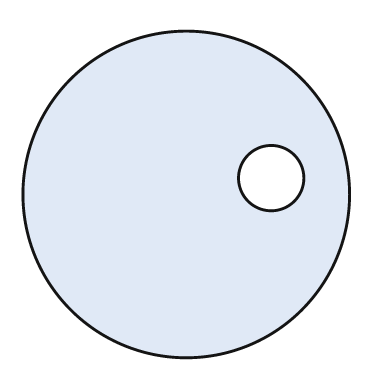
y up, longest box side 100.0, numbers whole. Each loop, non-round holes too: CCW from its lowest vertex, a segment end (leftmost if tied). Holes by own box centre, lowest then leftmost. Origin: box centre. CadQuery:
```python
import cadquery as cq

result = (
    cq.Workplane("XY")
    .moveTo(0.0, 0.0)
    .circle(50.0)
    .moveTo(26.0, 5.0)
    .circle(10.0)
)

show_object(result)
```